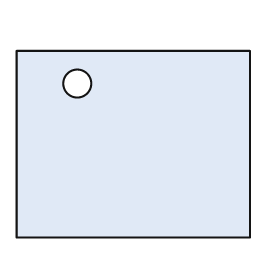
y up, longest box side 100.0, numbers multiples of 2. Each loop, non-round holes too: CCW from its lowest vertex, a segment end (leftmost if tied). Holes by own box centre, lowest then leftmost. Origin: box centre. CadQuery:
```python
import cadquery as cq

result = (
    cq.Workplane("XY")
    .moveTo(-50.0, -40.0)
    .lineTo(50.0, -40.0)
    .lineTo(50.0, 40.0)
    .lineTo(-50.0, 40.0)
    .close()
    .moveTo(-24.0, 26.0)
    .circle(6.0)
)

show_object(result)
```